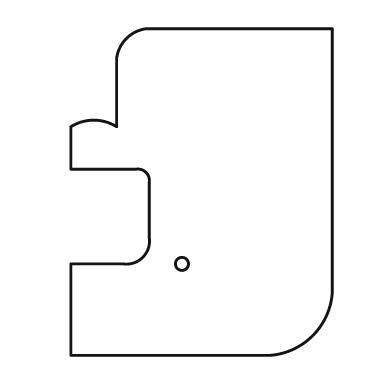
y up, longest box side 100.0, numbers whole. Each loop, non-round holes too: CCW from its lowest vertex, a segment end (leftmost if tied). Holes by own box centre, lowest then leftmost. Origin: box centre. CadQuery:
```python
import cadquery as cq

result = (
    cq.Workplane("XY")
    .moveTo(-40.0, -50.0)
    .lineTo(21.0, -50.0)
    .threePointArc((34.0, -44.0), (40.0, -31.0))
    .lineTo(40.0, 50.0)
    .lineTo(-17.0, 50.0)
    .threePointArc((-23.0, 47.0), (-26.0, 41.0))
    .lineTo(-26.0, 20.0)
    .threePointArc((-33.0, 22.0), (-40.0, 20.0))
    .lineTo(-40.0, 7.0)
    .lineTo(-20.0, 7.0)
    .threePointArc((-17.0, 6.0), (-16.0, 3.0))
    .lineTo(-16.0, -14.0)
    .threePointArc((-18.0, -20.0), (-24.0, -22.0))
    .lineTo(-40.0, -22.0)
    .close()
    .moveTo(-6.0, -22.0)
    .circle(2.0)
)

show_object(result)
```